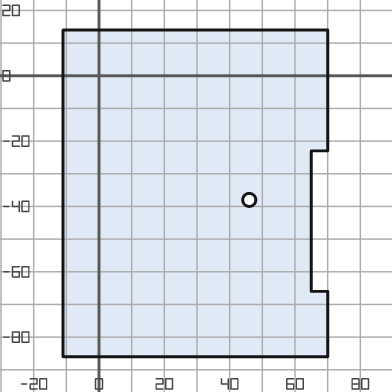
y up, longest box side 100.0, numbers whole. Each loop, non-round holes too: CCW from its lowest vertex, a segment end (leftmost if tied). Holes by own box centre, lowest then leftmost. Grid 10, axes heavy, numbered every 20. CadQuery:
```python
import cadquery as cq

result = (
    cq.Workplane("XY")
    .moveTo(-11.0, -86.0)
    .lineTo(70.0, -86.0)
    .lineTo(70.0, -66.0)
    .lineTo(65.0, -66.0)
    .lineTo(65.0, -23.0)
    .lineTo(70.0, -23.0)
    .lineTo(70.0, 14.0)
    .lineTo(-11.0, 14.0)
    .close()
    .moveTo(46.0, -38.0)
    .circle(2.0)
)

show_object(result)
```